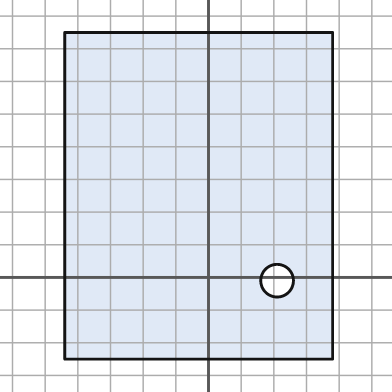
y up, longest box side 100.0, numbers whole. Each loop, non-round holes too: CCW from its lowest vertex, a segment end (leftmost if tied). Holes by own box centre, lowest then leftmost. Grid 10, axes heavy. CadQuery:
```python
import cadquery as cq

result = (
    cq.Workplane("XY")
    .moveTo(-44.0, -25.0)
    .lineTo(38.0, -25.0)
    .lineTo(38.0, 75.0)
    .lineTo(-44.0, 75.0)
    .close()
    .moveTo(21.0, -1.0)
    .circle(5.0)
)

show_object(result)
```